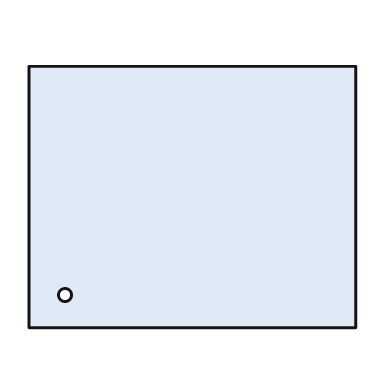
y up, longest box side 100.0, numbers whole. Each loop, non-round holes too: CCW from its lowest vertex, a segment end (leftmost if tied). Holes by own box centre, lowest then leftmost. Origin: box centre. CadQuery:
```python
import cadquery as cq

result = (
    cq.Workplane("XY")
    .moveTo(-50.0, -40.0)
    .lineTo(50.0, -40.0)
    .lineTo(50.0, 40.0)
    .lineTo(-50.0, 40.0)
    .close()
    .moveTo(-39.0, -30.0)
    .circle(2.0)
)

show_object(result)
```